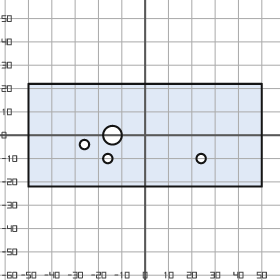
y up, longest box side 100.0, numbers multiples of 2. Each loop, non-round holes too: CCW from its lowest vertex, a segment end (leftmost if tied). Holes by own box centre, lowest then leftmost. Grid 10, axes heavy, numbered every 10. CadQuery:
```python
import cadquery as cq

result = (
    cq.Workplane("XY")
    .moveTo(-50.0, -22.0)
    .lineTo(50.0, -22.0)
    .lineTo(50.0, 22.0)
    .lineTo(-50.0, 22.0)
    .close()
    .moveTo(-16.0, -10.0)
    .circle(2.0)
    .moveTo(24.0, -10.0)
    .circle(2.0)
    .moveTo(-26.0, -4.0)
    .circle(2.0)
    .moveTo(-14.0, 0.0)
    .circle(4.0)
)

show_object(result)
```